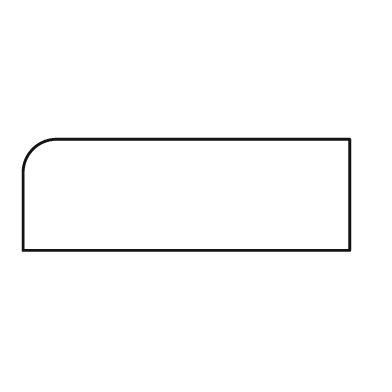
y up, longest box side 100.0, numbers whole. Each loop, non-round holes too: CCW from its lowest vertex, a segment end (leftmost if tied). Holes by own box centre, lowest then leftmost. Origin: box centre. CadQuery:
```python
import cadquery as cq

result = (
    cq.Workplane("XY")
    .moveTo(-50.0, -17.0)
    .lineTo(50.0, -17.0)
    .lineTo(50.0, 17.0)
    .lineTo(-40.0, 17.0)
    .threePointArc((-47.0, 14.0), (-50.0, 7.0))
    .close()
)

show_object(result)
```